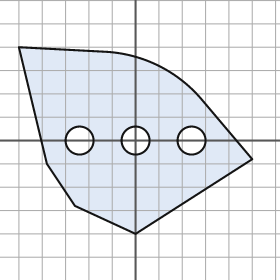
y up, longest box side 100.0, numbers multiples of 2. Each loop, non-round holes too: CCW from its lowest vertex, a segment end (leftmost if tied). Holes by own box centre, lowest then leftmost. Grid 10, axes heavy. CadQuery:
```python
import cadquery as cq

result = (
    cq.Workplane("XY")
    .moveTo(0.0, -40.0)
    .lineTo(50.0, -8.0)
    .lineTo(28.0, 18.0)
    .threePointArc((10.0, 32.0), (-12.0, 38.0))
    .lineTo(-50.0, 40.0)
    .lineTo(-38.0, -10.0)
    .lineTo(-26.0, -28.0)
    .close()
    .moveTo(-24.0, 0.0)
    .circle(6.0)
    .moveTo(0.0, 0.0)
    .circle(6.0)
    .moveTo(24.0, 0.0)
    .circle(6.0)
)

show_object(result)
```